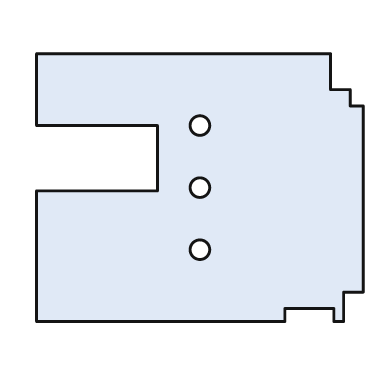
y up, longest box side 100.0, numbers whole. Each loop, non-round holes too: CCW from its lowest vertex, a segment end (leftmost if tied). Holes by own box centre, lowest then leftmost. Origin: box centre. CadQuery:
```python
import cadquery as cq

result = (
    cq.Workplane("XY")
    .moveTo(-50.0, -41.0)
    .lineTo(26.0, -41.0)
    .lineTo(26.0, -37.0)
    .lineTo(41.0, -37.0)
    .lineTo(41.0, -41.0)
    .lineTo(44.0, -41.0)
    .lineTo(44.0, -32.0)
    .lineTo(50.0, -32.0)
    .lineTo(50.0, 25.0)
    .lineTo(46.0, 25.0)
    .lineTo(46.0, 30.0)
    .lineTo(40.0, 30.0)
    .lineTo(40.0, 41.0)
    .lineTo(-50.0, 41.0)
    .lineTo(-50.0, 19.0)
    .lineTo(-13.0, 19.0)
    .lineTo(-13.0, -1.0)
    .lineTo(-50.0, -1.0)
    .close()
    .moveTo(0.0, -19.0)
    .circle(3.0)
    .moveTo(0.0, 0.0)
    .circle(3.0)
    .moveTo(0.0, 19.0)
    .circle(3.0)
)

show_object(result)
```